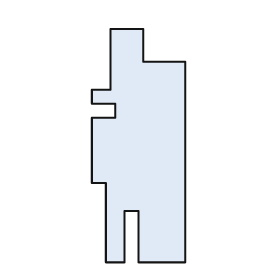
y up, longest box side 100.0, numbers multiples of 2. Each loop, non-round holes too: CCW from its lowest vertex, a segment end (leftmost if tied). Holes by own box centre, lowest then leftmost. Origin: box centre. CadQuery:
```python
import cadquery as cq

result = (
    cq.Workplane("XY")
    .moveTo(-14.0, -50.0)
    .lineTo(-6.0, -50.0)
    .lineTo(-6.0, -28.0)
    .lineTo(0.0, -28.0)
    .lineTo(0.0, -50.0)
    .lineTo(20.0, -50.0)
    .lineTo(20.0, 36.0)
    .lineTo(2.0, 36.0)
    .lineTo(2.0, 50.0)
    .lineTo(-12.0, 50.0)
    .lineTo(-12.0, 24.0)
    .lineTo(-20.0, 24.0)
    .lineTo(-20.0, 18.0)
    .lineTo(-10.0, 18.0)
    .lineTo(-10.0, 12.0)
    .lineTo(-20.0, 12.0)
    .lineTo(-20.0, -16.0)
    .lineTo(-14.0, -16.0)
    .close()
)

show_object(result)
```